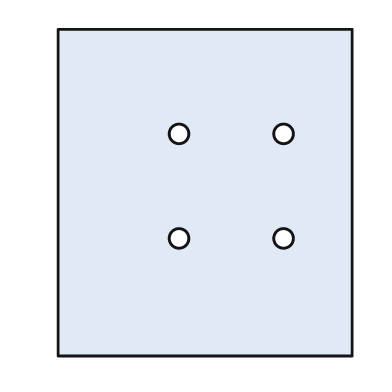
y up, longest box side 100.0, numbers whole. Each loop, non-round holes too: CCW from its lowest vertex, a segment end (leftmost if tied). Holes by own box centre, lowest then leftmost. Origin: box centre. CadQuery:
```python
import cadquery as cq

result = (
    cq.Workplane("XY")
    .moveTo(-45.0, -50.0)
    .lineTo(45.0, -50.0)
    .lineTo(45.0, 50.0)
    .lineTo(-45.0, 50.0)
    .close()
    .moveTo(-8.0, -14.0)
    .circle(3.0)
    .moveTo(24.0, -14.0)
    .circle(3.0)
    .moveTo(-8.0, 18.0)
    .circle(3.0)
    .moveTo(24.0, 18.0)
    .circle(3.0)
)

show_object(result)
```